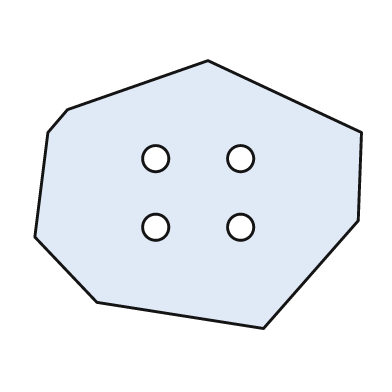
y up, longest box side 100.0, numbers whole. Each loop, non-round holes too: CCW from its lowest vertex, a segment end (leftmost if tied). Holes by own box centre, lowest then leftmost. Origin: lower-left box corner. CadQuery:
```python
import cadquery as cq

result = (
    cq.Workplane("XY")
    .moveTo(70.0, 0.0)
    .lineTo(99.0, 33.0)
    .lineTo(100.0, 60.0)
    .lineTo(53.0, 82.0)
    .lineTo(10.0, 67.0)
    .lineTo(4.0, 60.0)
    .lineTo(0.0, 28.0)
    .lineTo(19.0, 8.0)
    .close()
    .moveTo(37.0, 31.0)
    .circle(4.0)
    .moveTo(63.0, 31.0)
    .circle(4.0)
    .moveTo(37.0, 52.0)
    .circle(4.0)
    .moveTo(63.0, 52.0)
    .circle(4.0)
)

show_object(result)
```